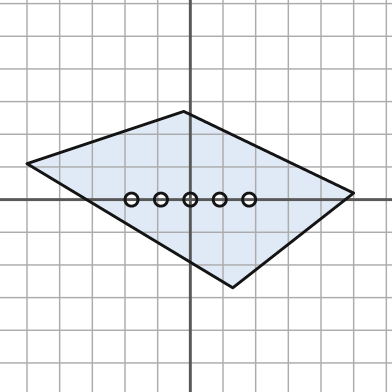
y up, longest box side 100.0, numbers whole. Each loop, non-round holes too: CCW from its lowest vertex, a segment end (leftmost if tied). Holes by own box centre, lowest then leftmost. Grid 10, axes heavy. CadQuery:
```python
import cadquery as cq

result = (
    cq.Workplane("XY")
    .moveTo(13.0, -27.0)
    .lineTo(50.0, 2.0)
    .lineTo(-2.0, 27.0)
    .lineTo(-50.0, 11.0)
    .close()
    .moveTo(-18.0, 0.0)
    .circle(2.0)
    .moveTo(-9.0, 0.0)
    .circle(2.0)
    .moveTo(0.0, 0.0)
    .circle(2.0)
    .moveTo(9.0, 0.0)
    .circle(2.0)
    .moveTo(18.0, 0.0)
    .circle(2.0)
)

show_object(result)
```